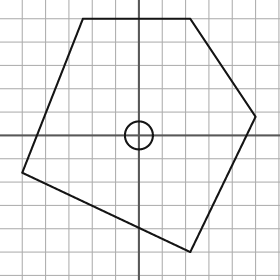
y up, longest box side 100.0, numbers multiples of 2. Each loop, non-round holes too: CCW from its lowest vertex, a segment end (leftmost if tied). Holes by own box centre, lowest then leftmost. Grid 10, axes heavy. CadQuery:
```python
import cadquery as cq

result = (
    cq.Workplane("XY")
    .moveTo(22.0, -50.0)
    .lineTo(50.0, 8.0)
    .lineTo(22.0, 50.0)
    .lineTo(-24.0, 50.0)
    .lineTo(-50.0, -16.0)
    .close()
    .moveTo(0.0, 0.0)
    .circle(6.0)
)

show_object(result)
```